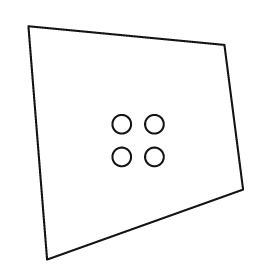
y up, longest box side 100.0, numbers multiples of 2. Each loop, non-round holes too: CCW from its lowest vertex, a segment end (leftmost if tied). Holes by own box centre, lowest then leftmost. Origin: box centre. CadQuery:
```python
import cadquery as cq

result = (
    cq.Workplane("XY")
    .moveTo(-38.0, -50.0)
    .lineTo(46.0, -20.0)
    .lineTo(38.0, 42.0)
    .lineTo(-46.0, 50.0)
    .close()
    .moveTo(-6.0, -6.0)
    .circle(4.0)
    .moveTo(8.0, -6.0)
    .circle(4.0)
    .moveTo(-6.0, 8.0)
    .circle(4.0)
    .moveTo(8.0, 8.0)
    .circle(4.0)
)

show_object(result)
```